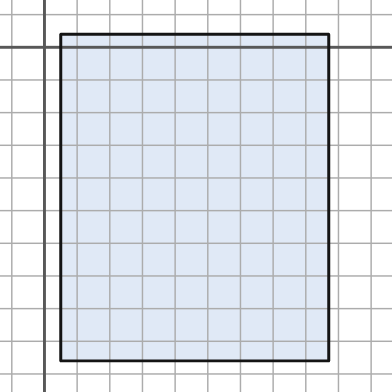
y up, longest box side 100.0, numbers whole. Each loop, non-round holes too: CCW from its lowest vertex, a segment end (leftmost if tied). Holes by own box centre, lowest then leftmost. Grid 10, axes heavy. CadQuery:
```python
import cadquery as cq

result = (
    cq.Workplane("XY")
    .moveTo(5.0, -96.0)
    .lineTo(87.0, -96.0)
    .lineTo(87.0, 4.0)
    .lineTo(5.0, 4.0)
    .close()
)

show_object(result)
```